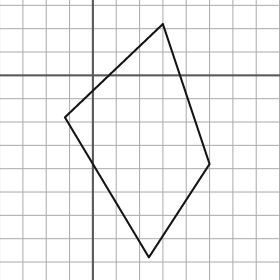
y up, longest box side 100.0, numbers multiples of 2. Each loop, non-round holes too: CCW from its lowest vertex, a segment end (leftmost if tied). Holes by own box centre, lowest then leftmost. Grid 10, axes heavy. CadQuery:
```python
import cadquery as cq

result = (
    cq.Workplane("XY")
    .moveTo(24.0, -78.0)
    .lineTo(50.0, -38.0)
    .lineTo(30.0, 22.0)
    .lineTo(-12.0, -18.0)
    .close()
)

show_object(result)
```